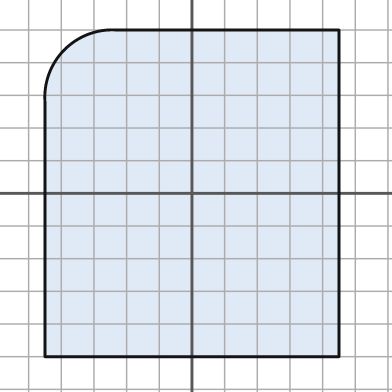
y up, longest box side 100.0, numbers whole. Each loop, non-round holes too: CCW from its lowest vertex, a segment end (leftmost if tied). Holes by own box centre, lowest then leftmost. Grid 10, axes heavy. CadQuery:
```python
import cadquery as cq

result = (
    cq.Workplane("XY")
    .moveTo(-45.0, -50.0)
    .lineTo(45.0, -50.0)
    .lineTo(45.0, 50.0)
    .lineTo(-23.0, 50.0)
    .threePointArc((-39.0, 44.0), (-45.0, 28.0))
    .close()
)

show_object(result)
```